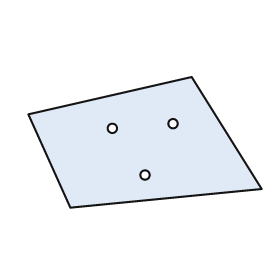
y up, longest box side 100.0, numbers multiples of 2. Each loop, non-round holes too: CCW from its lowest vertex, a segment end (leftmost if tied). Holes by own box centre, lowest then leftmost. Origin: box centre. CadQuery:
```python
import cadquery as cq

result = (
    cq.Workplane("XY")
    .moveTo(-32.0, -28.0)
    .lineTo(50.0, -20.0)
    .lineTo(20.0, 28.0)
    .lineTo(-50.0, 12.0)
    .close()
    .moveTo(0.0, -14.0)
    .circle(2.0)
    .moveTo(-14.0, 6.0)
    .circle(2.0)
    .moveTo(12.0, 8.0)
    .circle(2.0)
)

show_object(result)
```